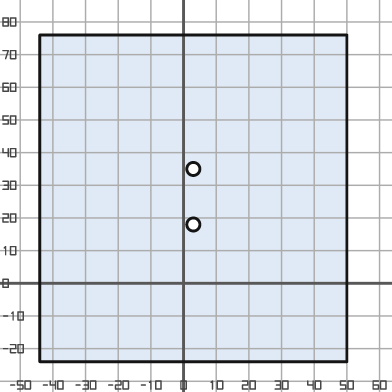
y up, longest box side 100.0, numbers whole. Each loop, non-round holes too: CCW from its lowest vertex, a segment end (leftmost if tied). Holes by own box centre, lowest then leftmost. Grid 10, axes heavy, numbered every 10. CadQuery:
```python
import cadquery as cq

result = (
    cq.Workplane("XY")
    .moveTo(-44.0, -24.0)
    .lineTo(50.0, -24.0)
    .lineTo(50.0, 76.0)
    .lineTo(-44.0, 76.0)
    .close()
    .moveTo(3.0, 18.0)
    .circle(2.0)
    .moveTo(3.0, 35.0)
    .circle(2.0)
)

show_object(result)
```